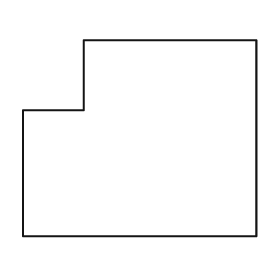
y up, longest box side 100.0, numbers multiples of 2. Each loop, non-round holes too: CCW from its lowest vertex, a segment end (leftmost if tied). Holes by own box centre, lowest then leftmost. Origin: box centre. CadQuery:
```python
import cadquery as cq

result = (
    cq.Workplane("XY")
    .moveTo(-50.0, -42.0)
    .lineTo(50.0, -42.0)
    .lineTo(50.0, 42.0)
    .lineTo(-24.0, 42.0)
    .lineTo(-24.0, 12.0)
    .lineTo(-50.0, 12.0)
    .close()
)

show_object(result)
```